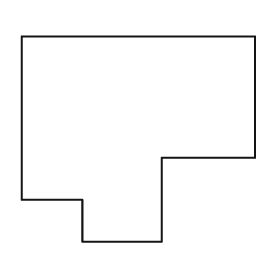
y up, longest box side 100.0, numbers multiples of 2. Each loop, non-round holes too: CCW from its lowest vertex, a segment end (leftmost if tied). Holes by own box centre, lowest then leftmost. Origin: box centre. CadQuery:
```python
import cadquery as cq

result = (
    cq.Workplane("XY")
    .moveTo(-24.0, -44.0)
    .lineTo(10.0, -44.0)
    .lineTo(10.0, -8.0)
    .lineTo(50.0, -8.0)
    .lineTo(50.0, 44.0)
    .lineTo(-50.0, 44.0)
    .lineTo(-50.0, -26.0)
    .lineTo(-24.0, -26.0)
    .close()
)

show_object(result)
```